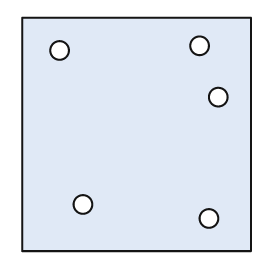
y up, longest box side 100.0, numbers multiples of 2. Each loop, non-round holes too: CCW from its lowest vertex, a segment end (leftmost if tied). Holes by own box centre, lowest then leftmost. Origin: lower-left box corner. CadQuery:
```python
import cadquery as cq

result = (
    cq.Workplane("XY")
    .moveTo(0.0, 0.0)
    .lineTo(98.0, 0.0)
    .lineTo(98.0, 100.0)
    .lineTo(0.0, 100.0)
    .close()
    .moveTo(80.0, 14.0)
    .circle(4.0)
    .moveTo(26.0, 20.0)
    .circle(4.0)
    .moveTo(84.0, 66.0)
    .circle(4.0)
    .moveTo(16.0, 86.0)
    .circle(4.0)
    .moveTo(76.0, 88.0)
    .circle(4.0)
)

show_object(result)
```